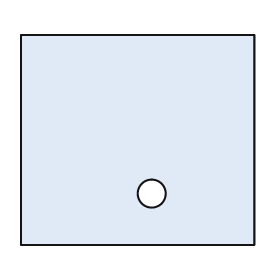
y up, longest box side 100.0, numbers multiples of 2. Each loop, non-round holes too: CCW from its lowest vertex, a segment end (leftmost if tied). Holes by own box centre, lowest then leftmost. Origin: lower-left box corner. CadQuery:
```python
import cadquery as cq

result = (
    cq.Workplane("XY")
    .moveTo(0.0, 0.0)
    .lineTo(100.0, 0.0)
    .lineTo(100.0, 90.0)
    .lineTo(0.0, 90.0)
    .close()
    .moveTo(56.0, 22.0)
    .circle(6.0)
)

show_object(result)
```